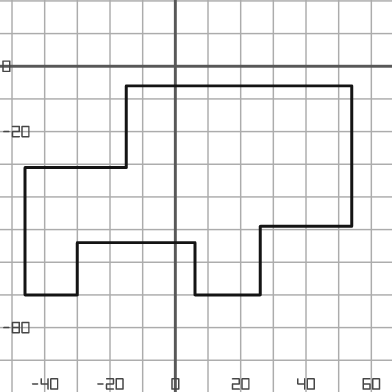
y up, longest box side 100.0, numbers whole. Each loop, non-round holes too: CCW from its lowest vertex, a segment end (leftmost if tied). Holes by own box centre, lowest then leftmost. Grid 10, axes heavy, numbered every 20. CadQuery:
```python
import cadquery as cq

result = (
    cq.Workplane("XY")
    .moveTo(-46.0, -70.0)
    .lineTo(-30.0, -70.0)
    .lineTo(-30.0, -54.0)
    .lineTo(6.0, -54.0)
    .lineTo(6.0, -70.0)
    .lineTo(26.0, -70.0)
    .lineTo(26.0, -49.0)
    .lineTo(54.0, -49.0)
    .lineTo(54.0, -6.0)
    .lineTo(-15.0, -6.0)
    .lineTo(-15.0, -31.0)
    .lineTo(-46.0, -31.0)
    .close()
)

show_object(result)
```